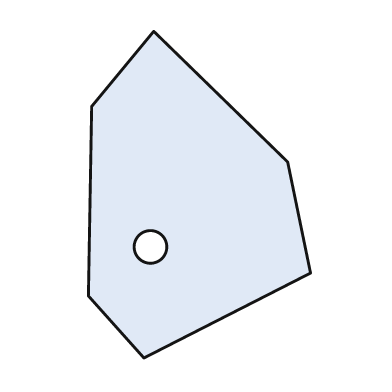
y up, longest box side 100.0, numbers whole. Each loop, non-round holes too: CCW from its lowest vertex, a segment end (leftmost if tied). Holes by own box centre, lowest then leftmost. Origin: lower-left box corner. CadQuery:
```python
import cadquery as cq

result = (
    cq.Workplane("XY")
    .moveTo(17.0, 0.0)
    .lineTo(68.0, 26.0)
    .lineTo(61.0, 60.0)
    .lineTo(20.0, 100.0)
    .lineTo(1.0, 77.0)
    .lineTo(0.0, 19.0)
    .close()
    .moveTo(19.0, 34.0)
    .circle(5.0)
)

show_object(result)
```